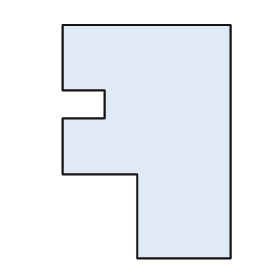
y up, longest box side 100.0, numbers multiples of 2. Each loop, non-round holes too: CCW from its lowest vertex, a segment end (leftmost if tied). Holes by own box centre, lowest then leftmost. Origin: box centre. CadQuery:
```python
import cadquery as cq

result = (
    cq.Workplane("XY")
    .moveTo(-4.0, -50.0)
    .lineTo(36.0, -50.0)
    .lineTo(36.0, 50.0)
    .lineTo(-36.0, 50.0)
    .lineTo(-36.0, 22.0)
    .lineTo(-18.0, 22.0)
    .lineTo(-18.0, 10.0)
    .lineTo(-36.0, 10.0)
    .lineTo(-36.0, -14.0)
    .lineTo(-4.0, -14.0)
    .close()
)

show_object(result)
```